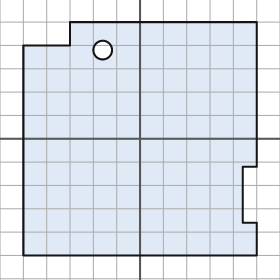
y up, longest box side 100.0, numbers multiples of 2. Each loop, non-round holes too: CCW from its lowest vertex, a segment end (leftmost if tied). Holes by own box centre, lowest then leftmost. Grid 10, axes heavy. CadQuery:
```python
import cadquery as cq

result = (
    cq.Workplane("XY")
    .moveTo(-50.0, -50.0)
    .lineTo(50.0, -50.0)
    .lineTo(50.0, -36.0)
    .lineTo(44.0, -36.0)
    .lineTo(44.0, -12.0)
    .lineTo(50.0, -12.0)
    .lineTo(50.0, 50.0)
    .lineTo(-30.0, 50.0)
    .lineTo(-30.0, 40.0)
    .lineTo(-50.0, 40.0)
    .close()
    .moveTo(-16.0, 38.0)
    .circle(4.0)
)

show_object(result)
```